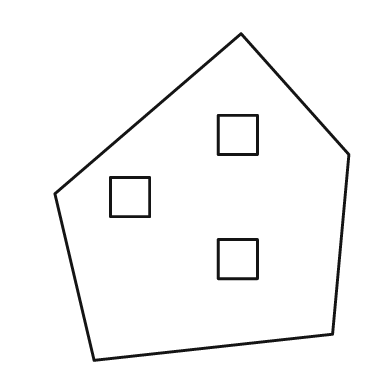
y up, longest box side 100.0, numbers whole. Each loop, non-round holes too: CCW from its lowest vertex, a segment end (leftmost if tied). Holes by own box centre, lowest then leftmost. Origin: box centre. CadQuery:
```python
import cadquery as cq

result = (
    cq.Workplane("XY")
    .moveTo(-33.0, -50.0)
    .lineTo(40.0, -42.0)
    .lineTo(45.0, 13.0)
    .lineTo(12.0, 50.0)
    .lineTo(-45.0, 1.0)
    .close()
    .moveTo(5.0, -25.0)
    .lineTo(17.0, -25.0)
    .lineTo(17.0, -13.0)
    .lineTo(5.0, -13.0)
    .close()
    .moveTo(-28.0, -6.0)
    .lineTo(-16.0, -6.0)
    .lineTo(-16.0, 6.0)
    .lineTo(-28.0, 6.0)
    .close()
    .moveTo(5.0, 13.0)
    .lineTo(17.0, 13.0)
    .lineTo(17.0, 25.0)
    .lineTo(5.0, 25.0)
    .close()
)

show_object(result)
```